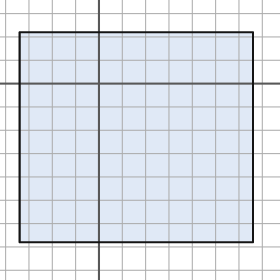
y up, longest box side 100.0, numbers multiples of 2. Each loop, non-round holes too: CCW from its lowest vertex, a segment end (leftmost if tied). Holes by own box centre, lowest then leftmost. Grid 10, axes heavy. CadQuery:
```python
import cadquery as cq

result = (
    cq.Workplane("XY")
    .moveTo(-34.0, -68.0)
    .lineTo(66.0, -68.0)
    .lineTo(66.0, 22.0)
    .lineTo(-34.0, 22.0)
    .close()
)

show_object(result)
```